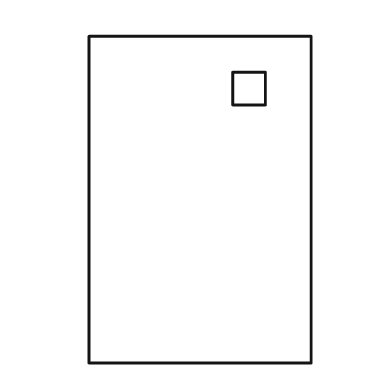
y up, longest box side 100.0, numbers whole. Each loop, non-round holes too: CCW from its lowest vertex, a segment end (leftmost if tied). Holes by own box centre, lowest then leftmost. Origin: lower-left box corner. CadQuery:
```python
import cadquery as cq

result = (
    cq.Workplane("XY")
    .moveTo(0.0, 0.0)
    .lineTo(68.0, 0.0)
    .lineTo(68.0, 100.0)
    .lineTo(0.0, 100.0)
    .close()
    .moveTo(44.0, 79.0)
    .lineTo(54.0, 79.0)
    .lineTo(54.0, 89.0)
    .lineTo(44.0, 89.0)
    .close()
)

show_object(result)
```